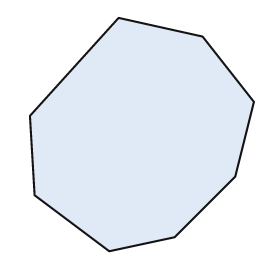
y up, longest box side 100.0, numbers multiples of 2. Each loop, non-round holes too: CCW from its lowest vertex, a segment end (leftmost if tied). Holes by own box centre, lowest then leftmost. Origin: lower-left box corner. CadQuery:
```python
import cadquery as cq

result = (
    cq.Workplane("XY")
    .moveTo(34.0, 0.0)
    .lineTo(62.0, 6.0)
    .lineTo(88.0, 32.0)
    .lineTo(96.0, 64.0)
    .lineTo(74.0, 92.0)
    .lineTo(38.0, 100.0)
    .lineTo(0.0, 58.0)
    .lineTo(2.0, 24.0)
    .close()
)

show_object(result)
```